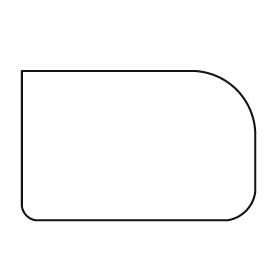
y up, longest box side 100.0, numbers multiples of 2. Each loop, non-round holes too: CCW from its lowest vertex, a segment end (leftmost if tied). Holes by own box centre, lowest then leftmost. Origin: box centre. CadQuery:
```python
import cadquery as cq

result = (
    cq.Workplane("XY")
    .moveTo(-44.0, -32.0)
    .lineTo(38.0, -32.0)
    .threePointArc((46.0, -28.0), (50.0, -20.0))
    .lineTo(50.0, 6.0)
    .threePointArc((42.0, 24.0), (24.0, 32.0))
    .lineTo(-50.0, 32.0)
    .lineTo(-50.0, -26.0)
    .threePointArc((-48.0, -30.0), (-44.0, -32.0))
    .close()
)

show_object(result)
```